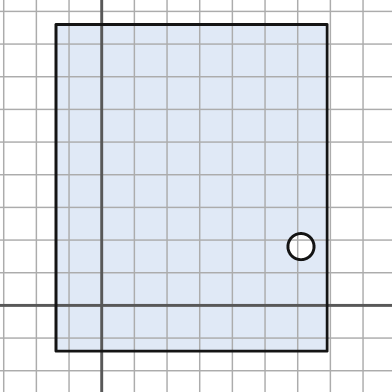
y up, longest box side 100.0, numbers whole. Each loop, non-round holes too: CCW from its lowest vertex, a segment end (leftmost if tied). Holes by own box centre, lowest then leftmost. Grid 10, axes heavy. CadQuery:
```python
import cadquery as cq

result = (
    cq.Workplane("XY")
    .moveTo(-14.0, -14.0)
    .lineTo(69.0, -14.0)
    .lineTo(69.0, 86.0)
    .lineTo(-14.0, 86.0)
    .close()
    .moveTo(61.0, 18.0)
    .circle(4.0)
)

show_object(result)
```